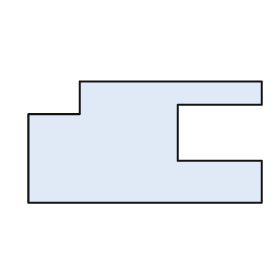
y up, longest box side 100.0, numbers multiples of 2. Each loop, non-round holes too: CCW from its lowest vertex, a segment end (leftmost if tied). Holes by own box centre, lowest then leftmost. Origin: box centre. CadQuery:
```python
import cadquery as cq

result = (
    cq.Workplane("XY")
    .moveTo(-50.0, -26.0)
    .lineTo(50.0, -26.0)
    .lineTo(50.0, -8.0)
    .lineTo(14.0, -8.0)
    .lineTo(14.0, 16.0)
    .lineTo(50.0, 16.0)
    .lineTo(50.0, 26.0)
    .lineTo(-28.0, 26.0)
    .lineTo(-28.0, 12.0)
    .lineTo(-50.0, 12.0)
    .close()
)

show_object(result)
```